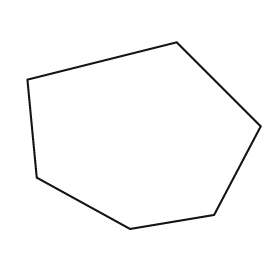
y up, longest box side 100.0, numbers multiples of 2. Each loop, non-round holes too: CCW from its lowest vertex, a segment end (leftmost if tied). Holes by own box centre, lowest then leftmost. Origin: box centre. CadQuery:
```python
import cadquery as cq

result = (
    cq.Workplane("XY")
    .moveTo(-6.0, -40.0)
    .lineTo(30.0, -34.0)
    .lineTo(50.0, 4.0)
    .lineTo(14.0, 40.0)
    .lineTo(-50.0, 24.0)
    .lineTo(-46.0, -18.0)
    .close()
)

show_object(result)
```